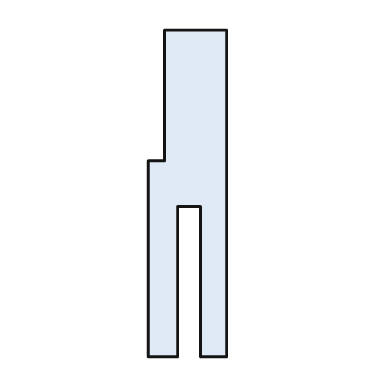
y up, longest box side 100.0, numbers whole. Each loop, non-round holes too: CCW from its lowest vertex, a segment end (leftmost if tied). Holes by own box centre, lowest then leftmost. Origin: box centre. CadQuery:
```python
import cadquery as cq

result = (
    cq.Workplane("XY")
    .moveTo(-12.0, -50.0)
    .lineTo(-3.0, -50.0)
    .lineTo(-3.0, -4.0)
    .lineTo(4.0, -4.0)
    .lineTo(4.0, -50.0)
    .lineTo(12.0, -50.0)
    .lineTo(12.0, 50.0)
    .lineTo(-7.0, 50.0)
    .lineTo(-7.0, 10.0)
    .lineTo(-12.0, 10.0)
    .close()
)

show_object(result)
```